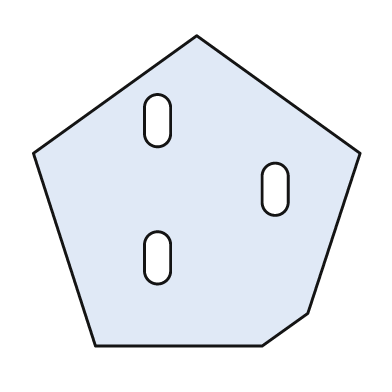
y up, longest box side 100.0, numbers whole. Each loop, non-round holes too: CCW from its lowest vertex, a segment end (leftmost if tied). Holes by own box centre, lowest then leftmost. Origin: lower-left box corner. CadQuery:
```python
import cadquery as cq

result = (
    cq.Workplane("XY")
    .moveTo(19.0, 0.0)
    .lineTo(70.0, 0.0)
    .lineTo(84.0, 10.0)
    .lineTo(100.0, 59.0)
    .lineTo(50.0, 95.0)
    .lineTo(0.0, 59.0)
    .close()
    .moveTo(34.0, 23.0)
    .threePointArc((38.0, 19.0), (42.0, 23.0))
    .lineTo(42.0, 31.0)
    .threePointArc((38.0, 35.0), (34.0, 31.0))
    .close()
    .moveTo(70.0, 44.0)
    .threePointArc((74.0, 40.0), (78.0, 44.0))
    .lineTo(78.0, 52.0)
    .threePointArc((74.0, 56.0), (70.0, 52.0))
    .close()
    .moveTo(34.0, 65.0)
    .threePointArc((38.0, 61.0), (42.0, 65.0))
    .lineTo(42.0, 73.0)
    .threePointArc((38.0, 77.0), (34.0, 73.0))
    .close()
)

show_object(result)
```